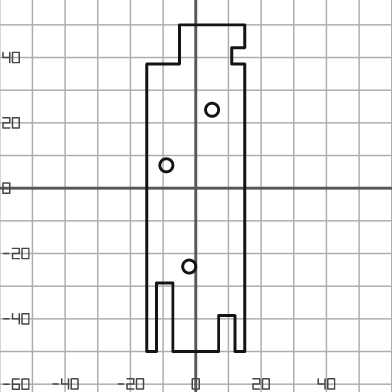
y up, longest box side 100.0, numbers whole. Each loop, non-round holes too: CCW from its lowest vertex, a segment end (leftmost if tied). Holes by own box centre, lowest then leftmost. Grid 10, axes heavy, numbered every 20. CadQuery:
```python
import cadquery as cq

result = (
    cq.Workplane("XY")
    .moveTo(-15.0, -50.0)
    .lineTo(-12.0, -50.0)
    .lineTo(-12.0, -29.0)
    .lineTo(-7.0, -29.0)
    .lineTo(-7.0, -50.0)
    .lineTo(7.0, -50.0)
    .lineTo(7.0, -39.0)
    .lineTo(12.0, -39.0)
    .lineTo(12.0, -50.0)
    .lineTo(15.0, -50.0)
    .lineTo(15.0, 38.0)
    .lineTo(11.0, 38.0)
    .lineTo(11.0, 43.0)
    .lineTo(15.0, 43.0)
    .lineTo(15.0, 50.0)
    .lineTo(-5.0, 50.0)
    .lineTo(-5.0, 38.0)
    .lineTo(-15.0, 38.0)
    .close()
    .moveTo(-2.0, -24.0)
    .circle(2.0)
    .moveTo(-9.0, 7.0)
    .circle(2.0)
    .moveTo(5.0, 24.0)
    .circle(2.0)
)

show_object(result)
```